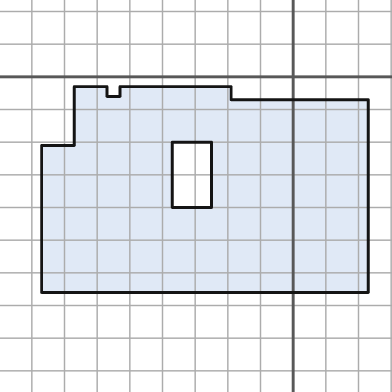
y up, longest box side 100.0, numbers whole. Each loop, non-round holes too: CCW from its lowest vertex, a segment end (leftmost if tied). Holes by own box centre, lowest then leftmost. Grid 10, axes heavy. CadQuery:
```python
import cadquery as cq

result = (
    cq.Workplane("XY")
    .moveTo(-77.0, -66.0)
    .lineTo(23.0, -66.0)
    .lineTo(23.0, -7.0)
    .lineTo(-19.0, -7.0)
    .lineTo(-19.0, -3.0)
    .lineTo(-53.0, -3.0)
    .lineTo(-53.0, -6.0)
    .lineTo(-57.0, -6.0)
    .lineTo(-57.0, -3.0)
    .lineTo(-67.0, -3.0)
    .lineTo(-67.0, -21.0)
    .lineTo(-77.0, -21.0)
    .close()
    .moveTo(-37.0, -40.0)
    .lineTo(-25.0, -40.0)
    .lineTo(-25.0, -20.0)
    .lineTo(-37.0, -20.0)
    .close()
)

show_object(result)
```